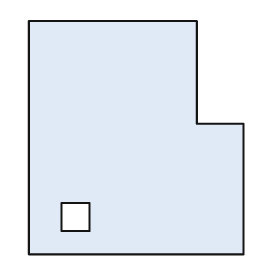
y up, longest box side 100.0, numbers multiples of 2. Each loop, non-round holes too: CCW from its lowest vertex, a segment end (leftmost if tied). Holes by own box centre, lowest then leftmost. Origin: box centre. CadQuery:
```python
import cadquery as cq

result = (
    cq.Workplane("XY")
    .moveTo(-46.0, -50.0)
    .lineTo(46.0, -50.0)
    .lineTo(46.0, 6.0)
    .lineTo(26.0, 6.0)
    .lineTo(26.0, 50.0)
    .lineTo(-46.0, 50.0)
    .close()
    .moveTo(-32.0, -40.0)
    .lineTo(-20.0, -40.0)
    .lineTo(-20.0, -28.0)
    .lineTo(-32.0, -28.0)
    .close()
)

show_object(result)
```